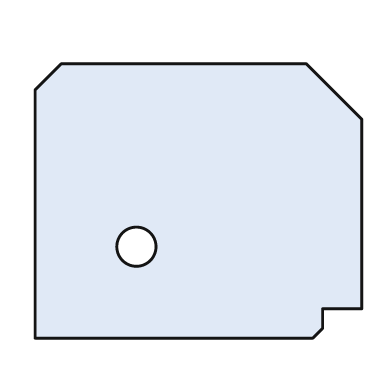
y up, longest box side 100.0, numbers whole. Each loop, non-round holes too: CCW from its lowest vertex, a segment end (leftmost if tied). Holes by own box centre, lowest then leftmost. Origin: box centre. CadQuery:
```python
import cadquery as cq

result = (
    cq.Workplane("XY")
    .moveTo(-50.0, -42.0)
    .lineTo(35.0, -42.0)
    .lineTo(38.0, -39.0)
    .lineTo(38.0, -33.0)
    .lineTo(50.0, -33.0)
    .lineTo(50.0, 25.0)
    .lineTo(33.0, 42.0)
    .lineTo(-42.0, 42.0)
    .lineTo(-50.0, 34.0)
    .close()
    .moveTo(-19.0, -14.0)
    .circle(6.0)
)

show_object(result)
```